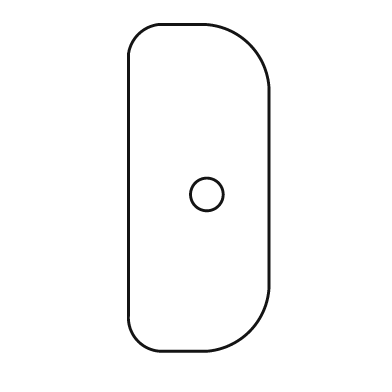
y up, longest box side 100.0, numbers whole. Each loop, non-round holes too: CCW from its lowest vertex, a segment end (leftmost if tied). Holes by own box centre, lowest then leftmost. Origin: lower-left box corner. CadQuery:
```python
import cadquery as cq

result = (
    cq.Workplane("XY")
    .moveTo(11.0, 0.0)
    .lineTo(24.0, 0.0)
    .threePointArc((37.0, 6.0), (43.0, 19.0))
    .lineTo(43.0, 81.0)
    .threePointArc((37.0, 94.0), (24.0, 100.0))
    .lineTo(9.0, 100.0)
    .threePointArc((3.0, 97.0), (0.0, 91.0))
    .lineTo(0.0, 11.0)
    .threePointArc((3.0, 3.0), (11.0, 0.0))
    .close()
    .moveTo(24.0, 48.0)
    .circle(5.0)
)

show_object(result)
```